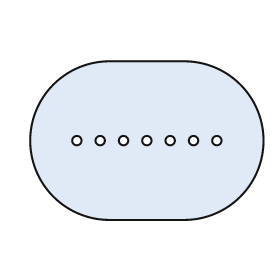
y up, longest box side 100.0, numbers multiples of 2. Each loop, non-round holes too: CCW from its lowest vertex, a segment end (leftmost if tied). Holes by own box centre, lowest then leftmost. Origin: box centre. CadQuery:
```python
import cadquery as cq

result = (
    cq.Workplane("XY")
    .moveTo(-16.0, -34.0)
    .lineTo(16.0, -34.0)
    .threePointArc((50.0, 0.0), (16.0, 34.0))
    .lineTo(-16.0, 34.0)
    .threePointArc((-50.0, 0.0), (-16.0, -34.0))
    .close()
    .moveTo(-30.0, 0.0)
    .circle(2.0)
    .moveTo(-20.0, 0.0)
    .circle(2.0)
    .moveTo(-10.0, 0.0)
    .circle(2.0)
    .moveTo(0.0, 0.0)
    .circle(2.0)
    .moveTo(10.0, 0.0)
    .circle(2.0)
    .moveTo(20.0, 0.0)
    .circle(2.0)
    .moveTo(30.0, 0.0)
    .circle(2.0)
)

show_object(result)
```